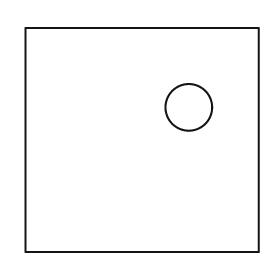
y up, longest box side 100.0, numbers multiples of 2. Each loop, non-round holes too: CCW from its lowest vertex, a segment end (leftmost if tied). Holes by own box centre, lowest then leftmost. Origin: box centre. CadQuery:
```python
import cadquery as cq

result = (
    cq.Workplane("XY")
    .moveTo(-50.0, -48.0)
    .lineTo(50.0, -48.0)
    .lineTo(50.0, 48.0)
    .lineTo(-50.0, 48.0)
    .close()
    .moveTo(20.0, 14.0)
    .circle(10.0)
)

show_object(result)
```